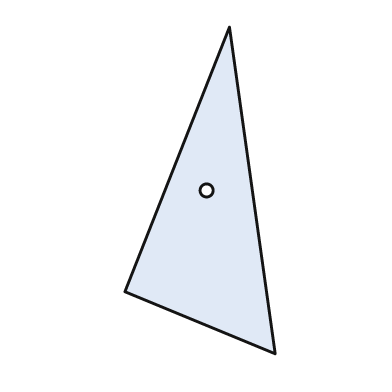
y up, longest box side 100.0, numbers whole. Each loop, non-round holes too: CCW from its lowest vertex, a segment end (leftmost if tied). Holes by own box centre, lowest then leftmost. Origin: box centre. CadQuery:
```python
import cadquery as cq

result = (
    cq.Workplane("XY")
    .moveTo(23.0, -50.0)
    .lineTo(9.0, 50.0)
    .lineTo(-23.0, -31.0)
    .close()
    .moveTo(2.0, 0.0)
    .circle(2.0)
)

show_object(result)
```